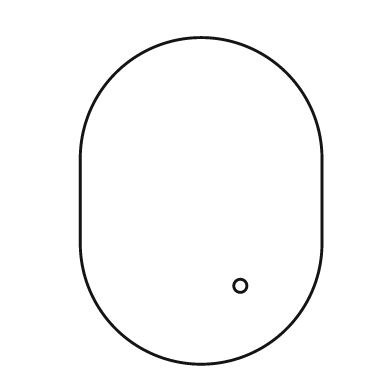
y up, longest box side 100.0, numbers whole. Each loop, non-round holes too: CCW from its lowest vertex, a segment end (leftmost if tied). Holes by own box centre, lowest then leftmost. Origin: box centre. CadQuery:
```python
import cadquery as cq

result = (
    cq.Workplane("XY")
    .moveTo(-37.0, -13.0)
    .threePointArc((0.0, -50.0), (37.0, -13.0))
    .lineTo(37.0, 13.0)
    .threePointArc((0.0, 50.0), (-37.0, 13.0))
    .close()
    .moveTo(12.0, -26.0)
    .circle(2.0)
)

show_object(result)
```